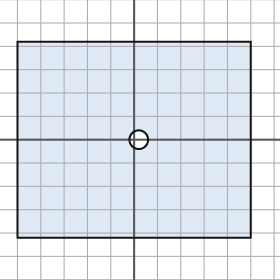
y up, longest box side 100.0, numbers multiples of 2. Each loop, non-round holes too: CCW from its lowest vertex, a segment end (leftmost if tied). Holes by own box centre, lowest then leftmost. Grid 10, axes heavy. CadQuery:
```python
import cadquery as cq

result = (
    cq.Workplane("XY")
    .moveTo(-50.0, -42.0)
    .lineTo(50.0, -42.0)
    .lineTo(50.0, 42.0)
    .lineTo(-50.0, 42.0)
    .close()
    .moveTo(2.0, 0.0)
    .circle(4.0)
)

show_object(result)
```